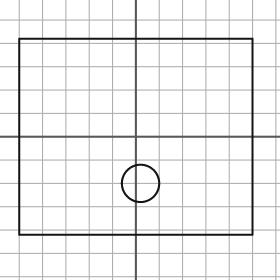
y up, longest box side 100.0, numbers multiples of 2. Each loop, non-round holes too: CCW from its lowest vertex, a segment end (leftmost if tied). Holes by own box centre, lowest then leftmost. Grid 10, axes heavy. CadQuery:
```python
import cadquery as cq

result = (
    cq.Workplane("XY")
    .moveTo(-50.0, -42.0)
    .lineTo(50.0, -42.0)
    .lineTo(50.0, 42.0)
    .lineTo(-50.0, 42.0)
    .close()
    .moveTo(2.0, -20.0)
    .circle(8.0)
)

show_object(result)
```